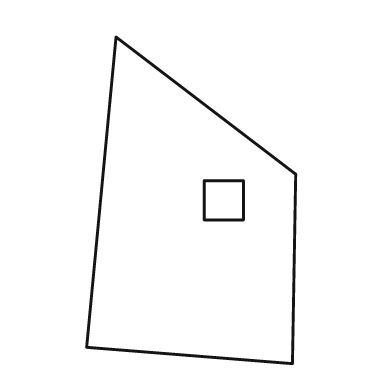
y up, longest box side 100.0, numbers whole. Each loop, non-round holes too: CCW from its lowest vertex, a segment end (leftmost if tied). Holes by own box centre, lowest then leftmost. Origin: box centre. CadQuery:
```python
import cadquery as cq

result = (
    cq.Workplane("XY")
    .moveTo(31.0, -50.0)
    .lineTo(32.0, 8.0)
    .lineTo(-23.0, 50.0)
    .lineTo(-32.0, -45.0)
    .close()
    .moveTo(4.0, -6.0)
    .lineTo(16.0, -6.0)
    .lineTo(16.0, 6.0)
    .lineTo(4.0, 6.0)
    .close()
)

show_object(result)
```